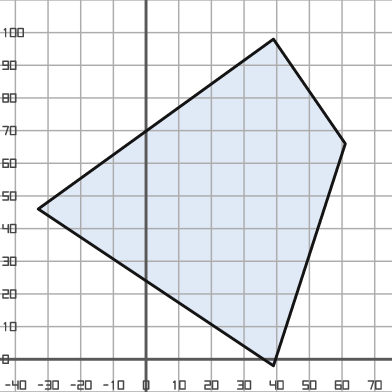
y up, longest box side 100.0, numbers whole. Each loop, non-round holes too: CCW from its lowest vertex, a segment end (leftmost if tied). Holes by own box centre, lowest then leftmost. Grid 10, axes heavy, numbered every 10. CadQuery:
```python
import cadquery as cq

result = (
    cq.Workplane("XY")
    .moveTo(39.0, -2.0)
    .lineTo(61.0, 66.0)
    .lineTo(39.0, 98.0)
    .lineTo(-33.0, 46.0)
    .close()
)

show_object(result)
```